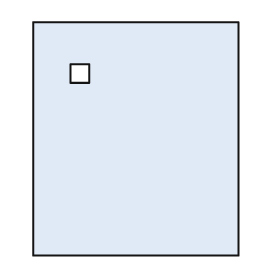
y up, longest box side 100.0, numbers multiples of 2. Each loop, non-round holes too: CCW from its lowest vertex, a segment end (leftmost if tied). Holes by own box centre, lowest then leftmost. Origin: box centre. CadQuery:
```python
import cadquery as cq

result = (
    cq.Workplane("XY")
    .moveTo(-44.0, -50.0)
    .lineTo(44.0, -50.0)
    .lineTo(44.0, 50.0)
    .lineTo(-44.0, 50.0)
    .close()
    .moveTo(-28.0, 24.0)
    .lineTo(-20.0, 24.0)
    .lineTo(-20.0, 32.0)
    .lineTo(-28.0, 32.0)
    .close()
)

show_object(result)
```